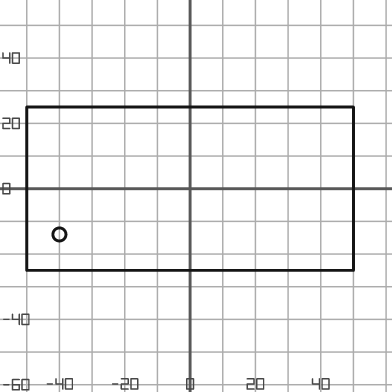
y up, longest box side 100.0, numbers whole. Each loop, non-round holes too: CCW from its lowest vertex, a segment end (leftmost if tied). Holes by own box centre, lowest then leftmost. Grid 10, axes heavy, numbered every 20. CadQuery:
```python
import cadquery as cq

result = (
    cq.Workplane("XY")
    .moveTo(-50.0, -25.0)
    .lineTo(50.0, -25.0)
    .lineTo(50.0, 25.0)
    .lineTo(-50.0, 25.0)
    .close()
    .moveTo(-40.0, -14.0)
    .circle(2.0)
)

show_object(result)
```